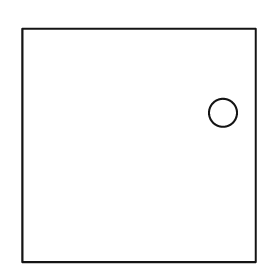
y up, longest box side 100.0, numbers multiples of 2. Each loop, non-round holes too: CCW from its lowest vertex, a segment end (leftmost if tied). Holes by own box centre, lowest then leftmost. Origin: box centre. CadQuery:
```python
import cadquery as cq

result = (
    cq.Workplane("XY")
    .moveTo(-50.0, -50.0)
    .lineTo(50.0, -50.0)
    .lineTo(50.0, 50.0)
    .lineTo(-50.0, 50.0)
    .close()
    .moveTo(36.0, 14.0)
    .circle(6.0)
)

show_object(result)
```